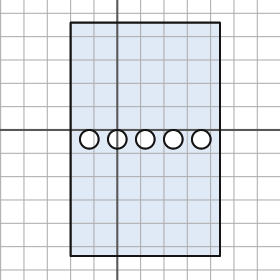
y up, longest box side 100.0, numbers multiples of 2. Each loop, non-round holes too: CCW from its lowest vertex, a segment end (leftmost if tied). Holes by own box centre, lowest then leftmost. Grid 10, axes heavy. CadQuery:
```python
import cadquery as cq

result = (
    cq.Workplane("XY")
    .moveTo(-20.0, -54.0)
    .lineTo(44.0, -54.0)
    .lineTo(44.0, 46.0)
    .lineTo(-20.0, 46.0)
    .close()
    .moveTo(-12.0, -4.0)
    .circle(4.0)
    .moveTo(0.0, -4.0)
    .circle(4.0)
    .moveTo(12.0, -4.0)
    .circle(4.0)
    .moveTo(24.0, -4.0)
    .circle(4.0)
    .moveTo(36.0, -4.0)
    .circle(4.0)
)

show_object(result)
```